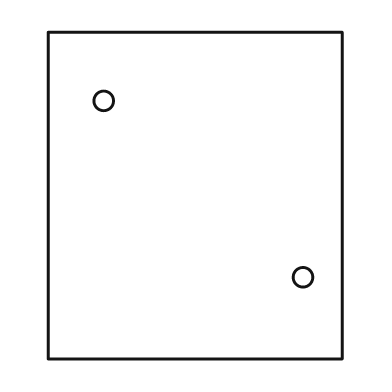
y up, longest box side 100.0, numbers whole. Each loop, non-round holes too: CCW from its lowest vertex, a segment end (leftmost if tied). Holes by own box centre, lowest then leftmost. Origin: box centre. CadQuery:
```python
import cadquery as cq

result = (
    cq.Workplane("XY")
    .moveTo(-45.0, -50.0)
    .lineTo(45.0, -50.0)
    .lineTo(45.0, 50.0)
    .lineTo(-45.0, 50.0)
    .close()
    .moveTo(33.0, -25.0)
    .circle(3.0)
    .moveTo(-28.0, 29.0)
    .circle(3.0)
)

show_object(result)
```